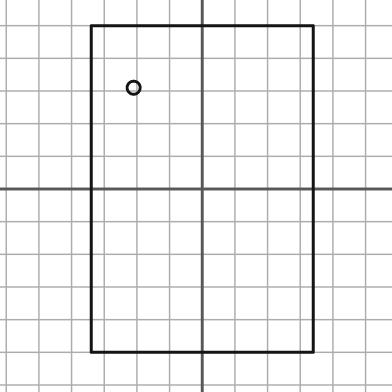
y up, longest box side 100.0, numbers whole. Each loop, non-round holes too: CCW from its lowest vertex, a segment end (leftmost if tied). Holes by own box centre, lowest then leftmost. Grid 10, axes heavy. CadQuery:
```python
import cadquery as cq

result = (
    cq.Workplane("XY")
    .moveTo(-34.0, -50.0)
    .lineTo(34.0, -50.0)
    .lineTo(34.0, 50.0)
    .lineTo(-34.0, 50.0)
    .close()
    .moveTo(-21.0, 31.0)
    .circle(2.0)
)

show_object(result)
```